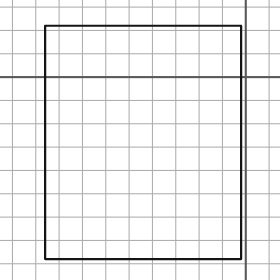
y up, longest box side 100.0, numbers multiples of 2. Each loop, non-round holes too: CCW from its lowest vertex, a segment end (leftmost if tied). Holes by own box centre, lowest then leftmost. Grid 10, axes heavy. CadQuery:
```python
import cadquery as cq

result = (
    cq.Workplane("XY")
    .moveTo(-86.0, -78.0)
    .lineTo(-2.0, -78.0)
    .lineTo(-2.0, 22.0)
    .lineTo(-86.0, 22.0)
    .close()
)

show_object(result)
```